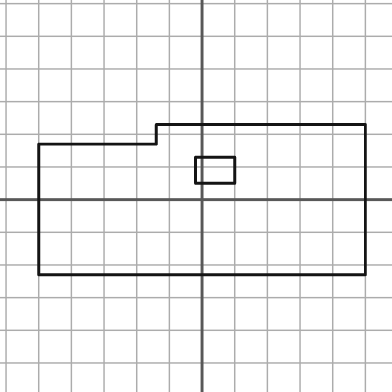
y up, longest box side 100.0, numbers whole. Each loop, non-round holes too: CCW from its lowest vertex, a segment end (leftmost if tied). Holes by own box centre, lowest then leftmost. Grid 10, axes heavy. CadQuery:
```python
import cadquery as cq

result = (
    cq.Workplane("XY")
    .moveTo(-50.0, -23.0)
    .lineTo(50.0, -23.0)
    .lineTo(50.0, 23.0)
    .lineTo(-14.0, 23.0)
    .lineTo(-14.0, 17.0)
    .lineTo(-50.0, 17.0)
    .close()
    .moveTo(-2.0, 5.0)
    .lineTo(10.0, 5.0)
    .lineTo(10.0, 13.0)
    .lineTo(-2.0, 13.0)
    .close()
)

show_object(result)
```